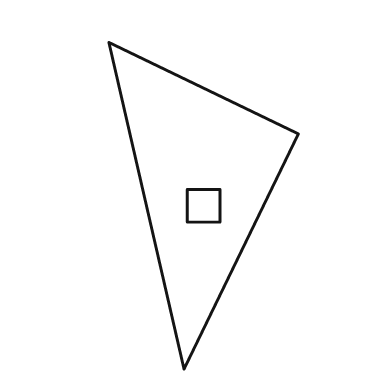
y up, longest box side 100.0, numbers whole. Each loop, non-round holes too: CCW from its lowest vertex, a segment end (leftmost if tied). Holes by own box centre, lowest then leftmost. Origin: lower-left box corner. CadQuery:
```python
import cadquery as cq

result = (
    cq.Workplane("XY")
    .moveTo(23.0, 0.0)
    .lineTo(58.0, 72.0)
    .lineTo(0.0, 100.0)
    .close()
    .moveTo(24.0, 45.0)
    .lineTo(34.0, 45.0)
    .lineTo(34.0, 55.0)
    .lineTo(24.0, 55.0)
    .close()
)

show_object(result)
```